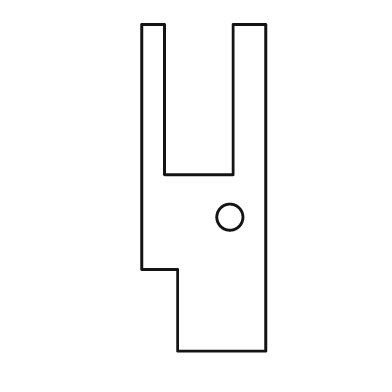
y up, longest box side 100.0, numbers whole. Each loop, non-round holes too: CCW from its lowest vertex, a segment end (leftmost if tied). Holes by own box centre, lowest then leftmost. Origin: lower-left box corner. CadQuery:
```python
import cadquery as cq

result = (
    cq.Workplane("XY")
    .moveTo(11.0, 0.0)
    .lineTo(38.0, 0.0)
    .lineTo(38.0, 100.0)
    .lineTo(28.0, 100.0)
    .lineTo(28.0, 54.0)
    .lineTo(7.0, 54.0)
    .lineTo(7.0, 100.0)
    .lineTo(0.0, 100.0)
    .lineTo(0.0, 25.0)
    .lineTo(11.0, 25.0)
    .close()
    .moveTo(27.0, 41.0)
    .circle(4.0)
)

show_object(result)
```